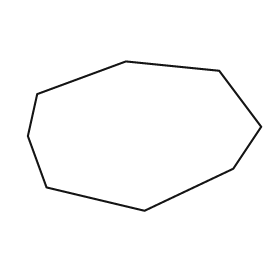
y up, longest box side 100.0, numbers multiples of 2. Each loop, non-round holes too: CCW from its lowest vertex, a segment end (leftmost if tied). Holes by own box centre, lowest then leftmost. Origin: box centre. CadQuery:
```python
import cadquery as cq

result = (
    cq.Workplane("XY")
    .moveTo(0.0, -32.0)
    .lineTo(38.0, -14.0)
    .lineTo(50.0, 4.0)
    .lineTo(32.0, 28.0)
    .lineTo(-8.0, 32.0)
    .lineTo(-46.0, 18.0)
    .lineTo(-50.0, 0.0)
    .lineTo(-42.0, -22.0)
    .close()
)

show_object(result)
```